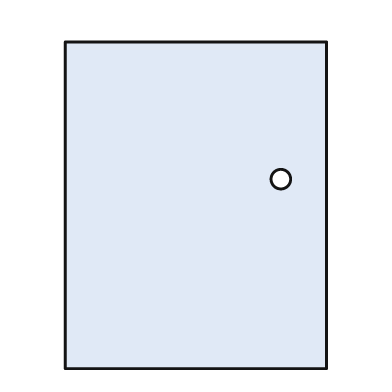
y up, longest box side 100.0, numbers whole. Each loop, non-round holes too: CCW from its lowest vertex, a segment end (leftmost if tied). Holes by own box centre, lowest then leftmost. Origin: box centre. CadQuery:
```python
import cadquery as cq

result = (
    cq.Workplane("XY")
    .moveTo(-40.0, -50.0)
    .lineTo(40.0, -50.0)
    .lineTo(40.0, 50.0)
    .lineTo(-40.0, 50.0)
    .close()
    .moveTo(26.0, 8.0)
    .circle(3.0)
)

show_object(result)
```